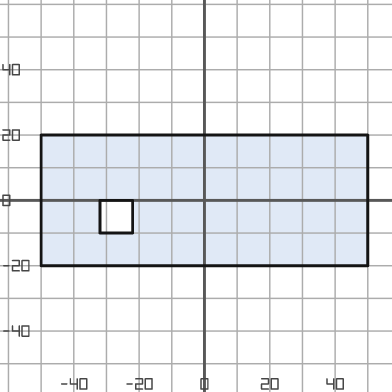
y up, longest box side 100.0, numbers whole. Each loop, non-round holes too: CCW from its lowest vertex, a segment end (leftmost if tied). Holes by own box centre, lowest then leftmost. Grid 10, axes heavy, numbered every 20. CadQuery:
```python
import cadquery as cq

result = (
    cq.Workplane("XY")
    .moveTo(-50.0, -20.0)
    .lineTo(50.0, -20.0)
    .lineTo(50.0, 20.0)
    .lineTo(-50.0, 20.0)
    .close()
    .moveTo(-32.0, -10.0)
    .lineTo(-22.0, -10.0)
    .lineTo(-22.0, 0.0)
    .lineTo(-32.0, 0.0)
    .close()
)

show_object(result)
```